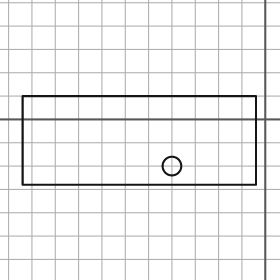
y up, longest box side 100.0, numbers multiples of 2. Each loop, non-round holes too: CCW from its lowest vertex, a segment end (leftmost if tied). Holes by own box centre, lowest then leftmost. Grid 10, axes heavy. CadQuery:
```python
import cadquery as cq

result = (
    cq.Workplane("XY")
    .moveTo(-104.0, -28.0)
    .lineTo(-4.0, -28.0)
    .lineTo(-4.0, 10.0)
    .lineTo(-104.0, 10.0)
    .close()
    .moveTo(-40.0, -20.0)
    .circle(4.0)
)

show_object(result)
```